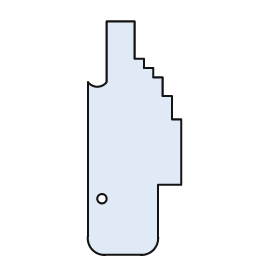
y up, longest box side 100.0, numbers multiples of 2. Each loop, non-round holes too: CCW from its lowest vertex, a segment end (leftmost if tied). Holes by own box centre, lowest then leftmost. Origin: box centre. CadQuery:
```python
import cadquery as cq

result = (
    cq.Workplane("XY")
    .moveTo(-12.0, -50.0)
    .lineTo(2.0, -50.0)
    .threePointArc((8.0, -48.0), (10.0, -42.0))
    .lineTo(10.0, -20.0)
    .lineTo(20.0, -20.0)
    .lineTo(20.0, 8.0)
    .lineTo(16.0, 8.0)
    .lineTo(16.0, 18.0)
    .lineTo(12.0, 18.0)
    .lineTo(12.0, 26.0)
    .lineTo(8.0, 26.0)
    .lineTo(8.0, 30.0)
    .lineTo(4.0, 30.0)
    .lineTo(4.0, 34.0)
    .lineTo(0.0, 34.0)
    .lineTo(0.0, 50.0)
    .lineTo(-12.0, 50.0)
    .lineTo(-12.0, 24.0)
    .threePointArc((-16.0, 22.0), (-20.0, 24.0))
    .lineTo(-20.0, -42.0)
    .threePointArc((-18.0, -48.0), (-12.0, -50.0))
    .close()
    .moveTo(-14.0, -26.0)
    .circle(2.0)
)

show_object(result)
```